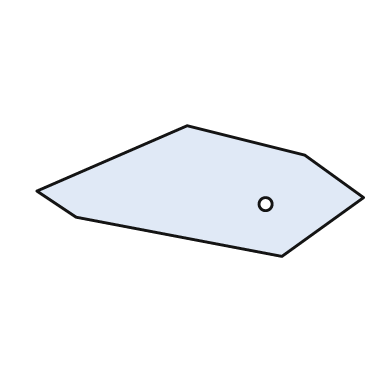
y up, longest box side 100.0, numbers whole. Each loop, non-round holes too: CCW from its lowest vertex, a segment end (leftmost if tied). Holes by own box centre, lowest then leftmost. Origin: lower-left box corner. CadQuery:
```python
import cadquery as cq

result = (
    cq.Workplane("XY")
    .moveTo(75.0, 0.0)
    .lineTo(100.0, 18.0)
    .lineTo(82.0, 31.0)
    .lineTo(46.0, 40.0)
    .lineTo(0.0, 20.0)
    .lineTo(12.0, 12.0)
    .close()
    .moveTo(70.0, 16.0)
    .circle(2.0)
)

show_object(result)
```